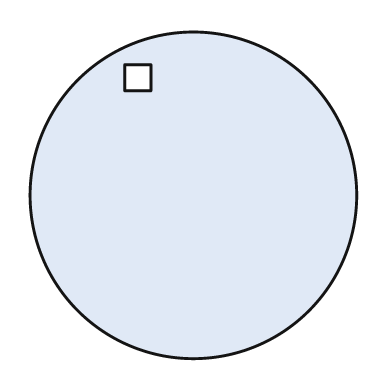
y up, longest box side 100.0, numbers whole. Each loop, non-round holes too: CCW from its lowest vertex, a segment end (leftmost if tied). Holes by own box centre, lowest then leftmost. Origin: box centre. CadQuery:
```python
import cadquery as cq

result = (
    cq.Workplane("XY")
    .moveTo(0.0, 0.0)
    .circle(50.0)
    .moveTo(-21.0, 32.0)
    .lineTo(-13.0, 32.0)
    .lineTo(-13.0, 40.0)
    .lineTo(-21.0, 40.0)
    .close()
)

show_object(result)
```